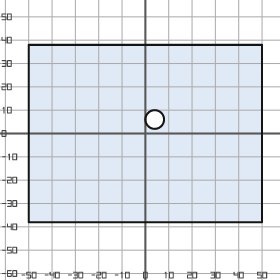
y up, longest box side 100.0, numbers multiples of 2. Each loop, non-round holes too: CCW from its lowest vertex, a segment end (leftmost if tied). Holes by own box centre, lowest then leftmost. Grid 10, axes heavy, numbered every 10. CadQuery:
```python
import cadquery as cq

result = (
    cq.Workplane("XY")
    .moveTo(-50.0, -38.0)
    .lineTo(50.0, -38.0)
    .lineTo(50.0, 38.0)
    .lineTo(-50.0, 38.0)
    .close()
    .moveTo(4.0, 6.0)
    .circle(4.0)
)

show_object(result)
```